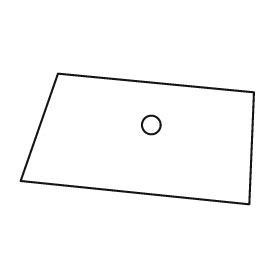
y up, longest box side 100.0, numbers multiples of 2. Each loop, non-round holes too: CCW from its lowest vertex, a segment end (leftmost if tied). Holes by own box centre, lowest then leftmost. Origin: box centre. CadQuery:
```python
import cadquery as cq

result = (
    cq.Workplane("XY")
    .moveTo(48.0, -28.0)
    .lineTo(50.0, 20.0)
    .lineTo(-34.0, 28.0)
    .lineTo(-50.0, -18.0)
    .close()
    .moveTo(6.0, 6.0)
    .circle(4.0)
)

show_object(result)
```